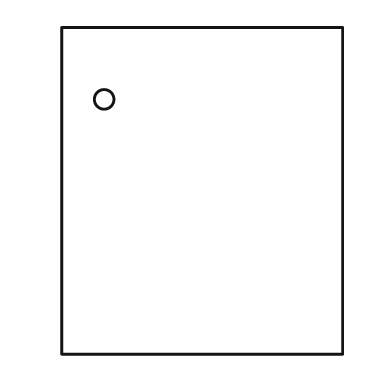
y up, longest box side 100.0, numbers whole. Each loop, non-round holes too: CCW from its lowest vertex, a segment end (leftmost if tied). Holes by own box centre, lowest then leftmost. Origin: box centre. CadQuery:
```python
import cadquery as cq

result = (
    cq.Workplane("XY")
    .moveTo(-43.0, -50.0)
    .lineTo(43.0, -50.0)
    .lineTo(43.0, 50.0)
    .lineTo(-43.0, 50.0)
    .close()
    .moveTo(-30.0, 28.0)
    .circle(3.0)
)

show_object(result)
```